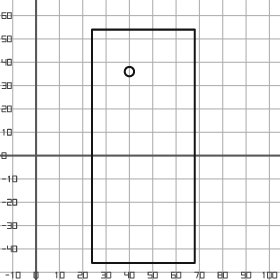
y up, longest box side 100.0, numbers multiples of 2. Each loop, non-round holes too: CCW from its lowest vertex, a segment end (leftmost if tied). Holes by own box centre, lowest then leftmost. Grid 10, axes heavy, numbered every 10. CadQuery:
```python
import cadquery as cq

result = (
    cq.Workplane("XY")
    .moveTo(24.0, -46.0)
    .lineTo(68.0, -46.0)
    .lineTo(68.0, 54.0)
    .lineTo(24.0, 54.0)
    .close()
    .moveTo(40.0, 36.0)
    .circle(2.0)
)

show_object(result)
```